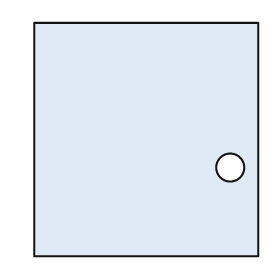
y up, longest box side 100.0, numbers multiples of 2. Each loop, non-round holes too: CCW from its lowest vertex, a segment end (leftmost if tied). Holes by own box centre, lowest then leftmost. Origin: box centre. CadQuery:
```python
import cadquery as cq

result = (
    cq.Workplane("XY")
    .moveTo(-48.0, -50.0)
    .lineTo(48.0, -50.0)
    .lineTo(48.0, 50.0)
    .lineTo(-48.0, 50.0)
    .close()
    .moveTo(36.0, -12.0)
    .circle(6.0)
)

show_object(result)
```